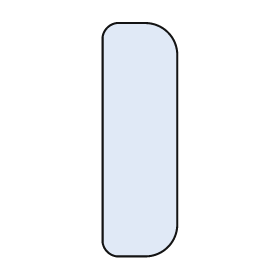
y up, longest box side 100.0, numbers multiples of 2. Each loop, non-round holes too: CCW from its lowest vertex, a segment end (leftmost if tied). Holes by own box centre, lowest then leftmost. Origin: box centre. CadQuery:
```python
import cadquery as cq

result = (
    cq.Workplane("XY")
    .moveTo(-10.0, -50.0)
    .lineTo(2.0, -50.0)
    .threePointArc((12.0, -46.0), (16.0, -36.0))
    .lineTo(16.0, 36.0)
    .threePointArc((12.0, 46.0), (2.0, 50.0))
    .lineTo(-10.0, 50.0)
    .threePointArc((-14.0, 48.0), (-16.0, 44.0))
    .lineTo(-16.0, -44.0)
    .threePointArc((-14.0, -48.0), (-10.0, -50.0))
    .close()
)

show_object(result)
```